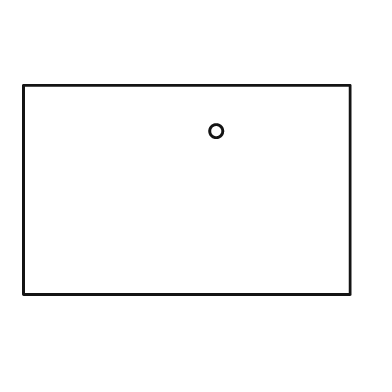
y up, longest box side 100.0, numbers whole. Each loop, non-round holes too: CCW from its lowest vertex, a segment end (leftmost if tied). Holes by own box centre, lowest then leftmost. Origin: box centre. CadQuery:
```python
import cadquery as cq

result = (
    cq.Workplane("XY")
    .moveTo(-50.0, -32.0)
    .lineTo(50.0, -32.0)
    .lineTo(50.0, 32.0)
    .lineTo(-50.0, 32.0)
    .close()
    .moveTo(9.0, 18.0)
    .circle(2.0)
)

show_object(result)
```